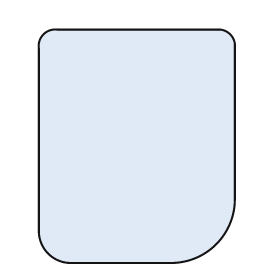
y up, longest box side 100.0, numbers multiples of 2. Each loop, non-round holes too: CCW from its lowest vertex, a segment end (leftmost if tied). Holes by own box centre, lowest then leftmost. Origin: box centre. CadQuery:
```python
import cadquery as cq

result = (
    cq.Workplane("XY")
    .moveTo(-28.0, -50.0)
    .lineTo(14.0, -50.0)
    .threePointArc((34.0, -42.0), (42.0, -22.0))
    .lineTo(42.0, 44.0)
    .threePointArc((40.0, 48.0), (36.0, 50.0))
    .lineTo(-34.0, 50.0)
    .threePointArc((-40.0, 48.0), (-42.0, 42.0))
    .lineTo(-42.0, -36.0)
    .threePointArc((-38.0, -46.0), (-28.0, -50.0))
    .close()
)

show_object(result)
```